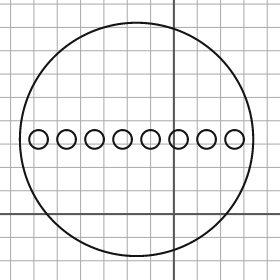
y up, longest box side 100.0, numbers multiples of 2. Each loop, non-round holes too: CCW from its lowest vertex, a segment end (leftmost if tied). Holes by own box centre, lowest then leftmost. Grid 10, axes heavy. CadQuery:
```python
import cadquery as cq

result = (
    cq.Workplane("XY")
    .moveTo(-16.0, 32.0)
    .circle(50.0)
    .moveTo(-58.0, 32.0)
    .circle(4.0)
    .moveTo(-46.0, 32.0)
    .circle(4.0)
    .moveTo(-34.0, 32.0)
    .circle(4.0)
    .moveTo(-22.0, 32.0)
    .circle(4.0)
    .moveTo(-10.0, 32.0)
    .circle(4.0)
    .moveTo(2.0, 32.0)
    .circle(4.0)
    .moveTo(14.0, 32.0)
    .circle(4.0)
    .moveTo(26.0, 32.0)
    .circle(4.0)
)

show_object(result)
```